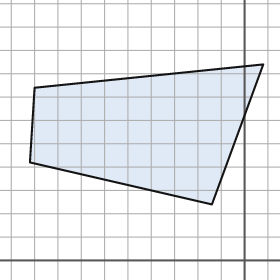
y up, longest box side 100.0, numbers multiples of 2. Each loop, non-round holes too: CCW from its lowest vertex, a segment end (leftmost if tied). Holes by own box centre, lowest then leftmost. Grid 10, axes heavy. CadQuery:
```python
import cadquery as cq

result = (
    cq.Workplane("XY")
    .moveTo(-14.0, 24.0)
    .lineTo(8.0, 84.0)
    .lineTo(-90.0, 74.0)
    .lineTo(-92.0, 42.0)
    .close()
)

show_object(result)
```